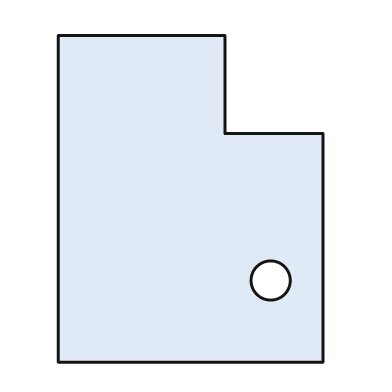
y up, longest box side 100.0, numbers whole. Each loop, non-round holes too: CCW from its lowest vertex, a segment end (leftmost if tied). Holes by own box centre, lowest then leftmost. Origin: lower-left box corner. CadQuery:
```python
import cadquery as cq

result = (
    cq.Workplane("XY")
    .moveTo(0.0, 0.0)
    .lineTo(81.0, 0.0)
    .lineTo(81.0, 70.0)
    .lineTo(51.0, 70.0)
    .lineTo(51.0, 100.0)
    .lineTo(0.0, 100.0)
    .close()
    .moveTo(65.0, 25.0)
    .circle(6.0)
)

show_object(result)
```